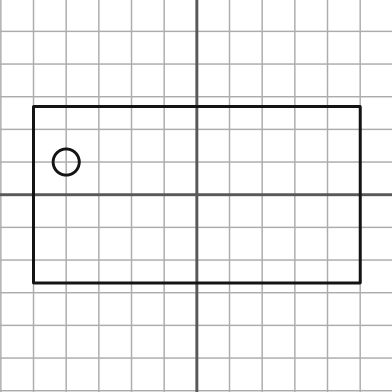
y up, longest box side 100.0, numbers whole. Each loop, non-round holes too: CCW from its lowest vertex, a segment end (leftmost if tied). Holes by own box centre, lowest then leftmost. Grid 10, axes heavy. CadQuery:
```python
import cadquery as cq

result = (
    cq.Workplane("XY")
    .moveTo(-50.0, -27.0)
    .lineTo(50.0, -27.0)
    .lineTo(50.0, 27.0)
    .lineTo(-50.0, 27.0)
    .close()
    .moveTo(-40.0, 10.0)
    .circle(4.0)
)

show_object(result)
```